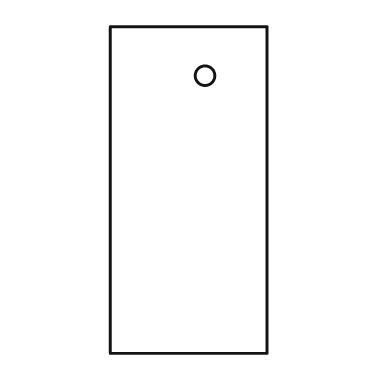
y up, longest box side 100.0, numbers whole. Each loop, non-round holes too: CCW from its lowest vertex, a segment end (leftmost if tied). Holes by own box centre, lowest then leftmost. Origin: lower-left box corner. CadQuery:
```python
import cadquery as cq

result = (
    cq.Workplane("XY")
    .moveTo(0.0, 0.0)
    .lineTo(48.0, 0.0)
    .lineTo(48.0, 100.0)
    .lineTo(0.0, 100.0)
    .close()
    .moveTo(29.0, 85.0)
    .circle(3.0)
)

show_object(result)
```